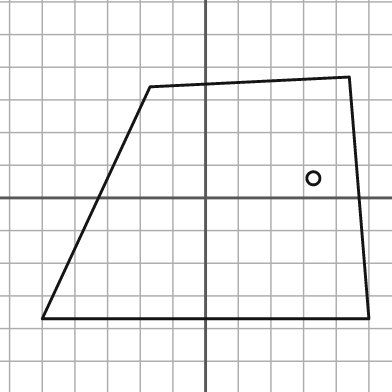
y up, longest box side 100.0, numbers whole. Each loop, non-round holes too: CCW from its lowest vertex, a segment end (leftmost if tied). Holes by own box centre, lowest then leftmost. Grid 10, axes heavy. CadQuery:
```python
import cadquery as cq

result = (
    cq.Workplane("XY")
    .moveTo(-50.0, -37.0)
    .lineTo(50.0, -37.0)
    .lineTo(44.0, 37.0)
    .lineTo(-17.0, 34.0)
    .close()
    .moveTo(33.0, 6.0)
    .circle(2.0)
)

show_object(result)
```